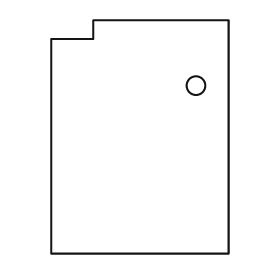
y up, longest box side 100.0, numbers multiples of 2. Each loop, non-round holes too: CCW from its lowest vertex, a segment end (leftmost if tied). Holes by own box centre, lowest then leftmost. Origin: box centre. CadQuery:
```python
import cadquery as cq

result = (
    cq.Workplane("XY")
    .moveTo(-38.0, -50.0)
    .lineTo(38.0, -50.0)
    .lineTo(38.0, 50.0)
    .lineTo(-20.0, 50.0)
    .lineTo(-20.0, 42.0)
    .lineTo(-38.0, 42.0)
    .close()
    .moveTo(24.0, 22.0)
    .circle(4.0)
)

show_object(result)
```